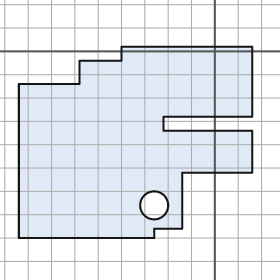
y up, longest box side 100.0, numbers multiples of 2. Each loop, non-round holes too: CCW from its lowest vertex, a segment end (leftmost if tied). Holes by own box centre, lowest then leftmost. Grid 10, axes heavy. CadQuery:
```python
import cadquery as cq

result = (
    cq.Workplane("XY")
    .moveTo(-84.0, -80.0)
    .lineTo(-26.0, -80.0)
    .lineTo(-26.0, -76.0)
    .lineTo(-14.0, -76.0)
    .lineTo(-14.0, -52.0)
    .lineTo(16.0, -52.0)
    .lineTo(16.0, -34.0)
    .lineTo(-22.0, -34.0)
    .lineTo(-22.0, -28.0)
    .lineTo(16.0, -28.0)
    .lineTo(16.0, 2.0)
    .lineTo(-40.0, 2.0)
    .lineTo(-40.0, -4.0)
    .lineTo(-58.0, -4.0)
    .lineTo(-58.0, -14.0)
    .lineTo(-84.0, -14.0)
    .close()
    .moveTo(-26.0, -66.0)
    .circle(6.0)
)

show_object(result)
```